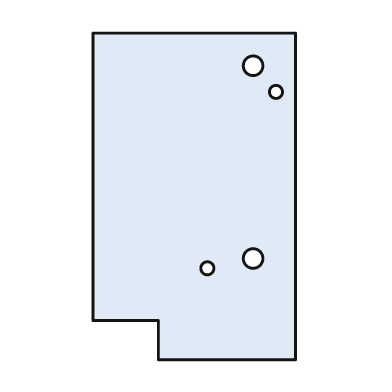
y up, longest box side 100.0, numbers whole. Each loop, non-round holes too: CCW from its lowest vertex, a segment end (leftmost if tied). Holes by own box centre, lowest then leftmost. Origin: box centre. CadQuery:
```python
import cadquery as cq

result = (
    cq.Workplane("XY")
    .moveTo(-11.0, -50.0)
    .lineTo(31.0, -50.0)
    .lineTo(31.0, 50.0)
    .lineTo(-31.0, 50.0)
    .lineTo(-31.0, -38.0)
    .lineTo(-11.0, -38.0)
    .close()
    .moveTo(4.0, -22.0)
    .circle(2.0)
    .moveTo(18.0, -19.0)
    .circle(3.0)
    .moveTo(25.0, 32.0)
    .circle(2.0)
    .moveTo(18.0, 40.0)
    .circle(3.0)
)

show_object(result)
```